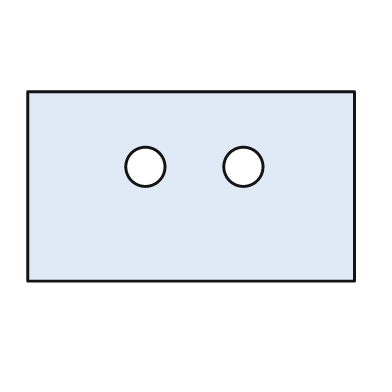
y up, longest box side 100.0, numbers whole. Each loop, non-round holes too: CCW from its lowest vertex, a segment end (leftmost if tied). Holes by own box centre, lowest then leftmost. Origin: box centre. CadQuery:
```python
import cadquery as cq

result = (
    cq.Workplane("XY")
    .moveTo(-50.0, -29.0)
    .lineTo(50.0, -29.0)
    .lineTo(50.0, 29.0)
    .lineTo(-50.0, 29.0)
    .close()
    .moveTo(-14.0, 6.0)
    .circle(6.0)
    .moveTo(16.0, 6.0)
    .circle(6.0)
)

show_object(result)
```